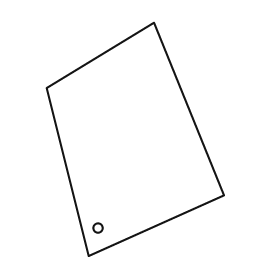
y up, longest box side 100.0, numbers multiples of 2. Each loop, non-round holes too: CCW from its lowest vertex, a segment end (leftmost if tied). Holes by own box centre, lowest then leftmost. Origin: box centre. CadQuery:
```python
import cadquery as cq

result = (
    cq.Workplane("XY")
    .moveTo(-20.0, -50.0)
    .lineTo(38.0, -24.0)
    .lineTo(8.0, 50.0)
    .lineTo(-38.0, 22.0)
    .close()
    .moveTo(-16.0, -38.0)
    .circle(2.0)
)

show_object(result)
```